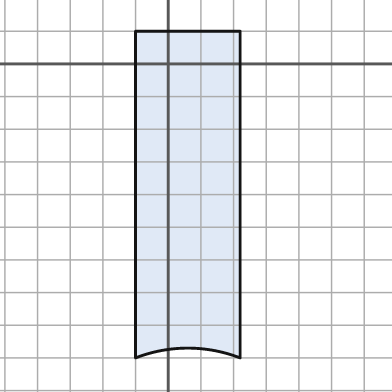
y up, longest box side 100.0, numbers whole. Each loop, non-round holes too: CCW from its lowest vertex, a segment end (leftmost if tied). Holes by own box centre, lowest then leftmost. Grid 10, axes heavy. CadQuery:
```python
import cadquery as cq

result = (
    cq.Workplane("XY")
    .moveTo(-10.0, -90.0)
    .threePointArc((6.0, -87.0), (22.0, -90.0))
    .lineTo(22.0, 10.0)
    .lineTo(-10.0, 10.0)
    .close()
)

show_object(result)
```